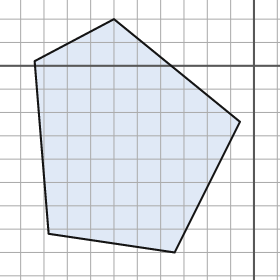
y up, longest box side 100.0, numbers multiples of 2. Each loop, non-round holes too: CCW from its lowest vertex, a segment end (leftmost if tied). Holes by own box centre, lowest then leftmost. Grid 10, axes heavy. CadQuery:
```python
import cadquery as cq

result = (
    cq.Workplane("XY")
    .moveTo(-34.0, -80.0)
    .lineTo(-6.0, -24.0)
    .lineTo(-60.0, 20.0)
    .lineTo(-94.0, 2.0)
    .lineTo(-88.0, -72.0)
    .close()
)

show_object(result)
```